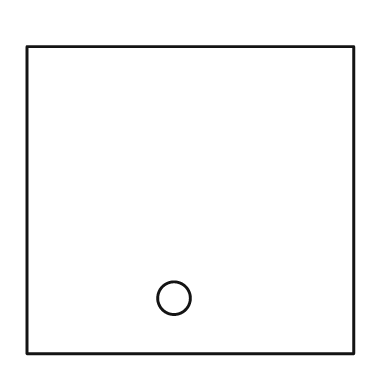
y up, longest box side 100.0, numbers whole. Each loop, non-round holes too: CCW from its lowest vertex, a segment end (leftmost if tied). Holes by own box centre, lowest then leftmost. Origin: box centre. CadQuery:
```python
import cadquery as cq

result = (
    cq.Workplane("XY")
    .moveTo(-50.0, -47.0)
    .lineTo(50.0, -47.0)
    .lineTo(50.0, 47.0)
    .lineTo(-50.0, 47.0)
    .close()
    .moveTo(-5.0, -30.0)
    .circle(5.0)
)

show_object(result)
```